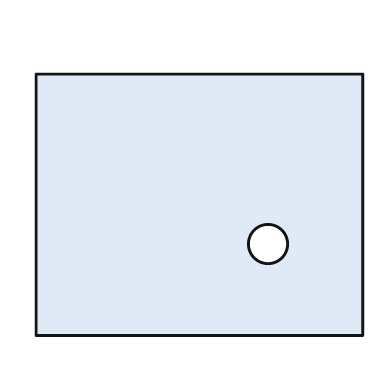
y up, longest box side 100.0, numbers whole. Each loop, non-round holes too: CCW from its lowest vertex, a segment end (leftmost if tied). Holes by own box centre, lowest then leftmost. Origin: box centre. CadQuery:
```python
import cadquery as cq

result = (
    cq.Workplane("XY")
    .moveTo(-50.0, -40.0)
    .lineTo(50.0, -40.0)
    .lineTo(50.0, 40.0)
    .lineTo(-50.0, 40.0)
    .close()
    .moveTo(21.0, -12.0)
    .circle(6.0)
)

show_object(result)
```